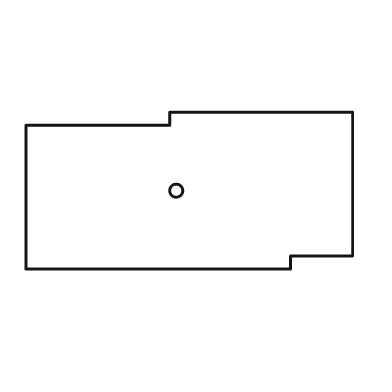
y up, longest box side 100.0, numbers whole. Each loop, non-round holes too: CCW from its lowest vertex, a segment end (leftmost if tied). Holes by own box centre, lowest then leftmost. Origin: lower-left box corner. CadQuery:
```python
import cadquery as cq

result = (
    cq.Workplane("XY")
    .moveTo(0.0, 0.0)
    .lineTo(81.0, 0.0)
    .lineTo(81.0, 4.0)
    .lineTo(100.0, 4.0)
    .lineTo(100.0, 48.0)
    .lineTo(44.0, 48.0)
    .lineTo(44.0, 44.0)
    .lineTo(0.0, 44.0)
    .close()
    .moveTo(46.0, 24.0)
    .circle(2.0)
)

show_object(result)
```